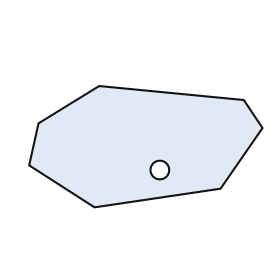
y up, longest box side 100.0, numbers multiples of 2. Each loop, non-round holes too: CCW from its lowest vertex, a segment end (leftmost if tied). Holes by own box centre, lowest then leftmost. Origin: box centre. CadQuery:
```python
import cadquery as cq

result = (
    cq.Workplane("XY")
    .moveTo(-22.0, -26.0)
    .lineTo(32.0, -18.0)
    .lineTo(50.0, 8.0)
    .lineTo(42.0, 20.0)
    .lineTo(-20.0, 26.0)
    .lineTo(-46.0, 10.0)
    .lineTo(-50.0, -8.0)
    .close()
    .moveTo(6.0, -10.0)
    .circle(4.0)
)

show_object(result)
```